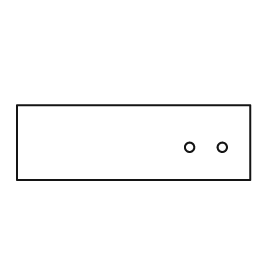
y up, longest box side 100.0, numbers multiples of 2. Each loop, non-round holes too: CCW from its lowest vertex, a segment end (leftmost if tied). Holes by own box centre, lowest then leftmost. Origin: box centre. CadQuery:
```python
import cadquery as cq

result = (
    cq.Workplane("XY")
    .moveTo(-50.0, -16.0)
    .lineTo(50.0, -16.0)
    .lineTo(50.0, 16.0)
    .lineTo(-50.0, 16.0)
    .close()
    .moveTo(24.0, -2.0)
    .circle(2.0)
    .moveTo(38.0, -2.0)
    .circle(2.0)
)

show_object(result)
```